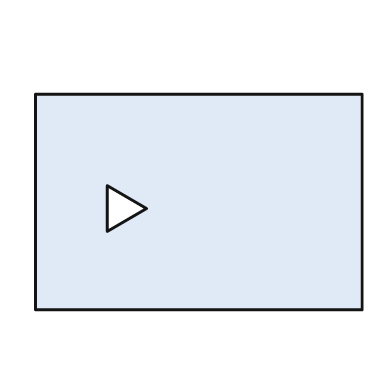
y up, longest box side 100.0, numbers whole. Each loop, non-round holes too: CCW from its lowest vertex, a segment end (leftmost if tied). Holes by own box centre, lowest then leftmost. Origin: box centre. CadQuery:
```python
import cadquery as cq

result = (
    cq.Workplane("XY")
    .moveTo(-50.0, -33.0)
    .lineTo(50.0, -33.0)
    .lineTo(50.0, 33.0)
    .lineTo(-50.0, 33.0)
    .close()
    .moveTo(-28.0, -9.0)
    .lineTo(-16.0, -2.0)
    .lineTo(-28.0, 5.0)
    .close()
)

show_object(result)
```